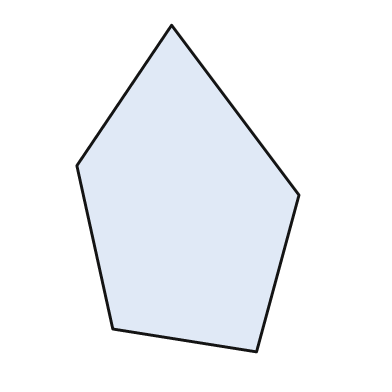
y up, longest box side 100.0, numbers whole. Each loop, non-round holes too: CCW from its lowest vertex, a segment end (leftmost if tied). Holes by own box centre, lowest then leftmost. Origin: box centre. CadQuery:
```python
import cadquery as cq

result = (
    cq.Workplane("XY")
    .moveTo(21.0, -50.0)
    .lineTo(34.0, -2.0)
    .lineTo(-5.0, 50.0)
    .lineTo(-34.0, 7.0)
    .lineTo(-23.0, -43.0)
    .close()
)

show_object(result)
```